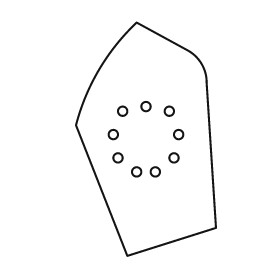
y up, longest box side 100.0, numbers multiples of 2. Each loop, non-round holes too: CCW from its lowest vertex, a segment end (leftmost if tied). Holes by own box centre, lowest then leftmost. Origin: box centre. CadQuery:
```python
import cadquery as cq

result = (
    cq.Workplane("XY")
    .moveTo(-8.0, -50.0)
    .lineTo(30.0, -38.0)
    .lineTo(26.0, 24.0)
    .threePointArc((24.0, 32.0), (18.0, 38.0))
    .lineTo(-4.0, 50.0)
    .threePointArc((-20.0, 30.0), (-30.0, 6.0))
    .close()
    .moveTo(-4.0, -14.0)
    .circle(2.0)
    .moveTo(4.0, -14.0)
    .circle(2.0)
    .moveTo(-12.0, -8.0)
    .circle(2.0)
    .moveTo(12.0, -8.0)
    .circle(2.0)
    .moveTo(-14.0, 2.0)
    .circle(2.0)
    .moveTo(14.0, 2.0)
    .circle(2.0)
    .moveTo(-10.0, 12.0)
    .circle(2.0)
    .moveTo(10.0, 12.0)
    .circle(2.0)
    .moveTo(0.0, 14.0)
    .circle(2.0)
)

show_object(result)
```